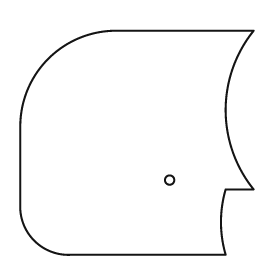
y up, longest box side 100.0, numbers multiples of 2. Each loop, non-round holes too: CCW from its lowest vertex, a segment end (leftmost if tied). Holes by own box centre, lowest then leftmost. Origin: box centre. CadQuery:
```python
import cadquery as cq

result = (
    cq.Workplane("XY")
    .moveTo(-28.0, -48.0)
    .lineTo(38.0, -48.0)
    .threePointArc((36.0, -34.0), (38.0, -20.0))
    .lineTo(50.0, -20.0)
    .threePointArc((38.0, 14.0), (50.0, 48.0))
    .lineTo(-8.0, 48.0)
    .threePointArc((-38.0, 36.0), (-50.0, 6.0))
    .lineTo(-50.0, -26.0)
    .threePointArc((-44.0, -42.0), (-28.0, -48.0))
    .close()
    .moveTo(14.0, -16.0)
    .circle(2.0)
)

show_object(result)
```